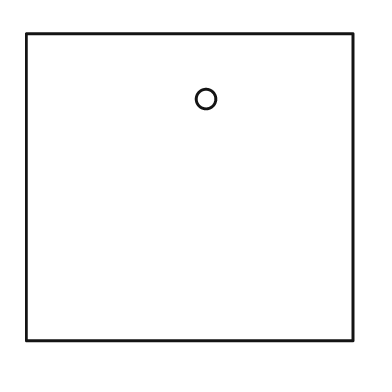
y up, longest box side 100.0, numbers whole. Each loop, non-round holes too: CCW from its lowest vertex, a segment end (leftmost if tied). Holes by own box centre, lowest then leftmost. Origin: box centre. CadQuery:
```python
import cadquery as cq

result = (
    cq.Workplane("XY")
    .moveTo(-50.0, -47.0)
    .lineTo(50.0, -47.0)
    .lineTo(50.0, 47.0)
    .lineTo(-50.0, 47.0)
    .close()
    .moveTo(5.0, 27.0)
    .circle(3.0)
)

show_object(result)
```